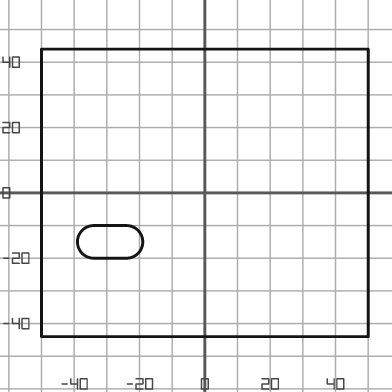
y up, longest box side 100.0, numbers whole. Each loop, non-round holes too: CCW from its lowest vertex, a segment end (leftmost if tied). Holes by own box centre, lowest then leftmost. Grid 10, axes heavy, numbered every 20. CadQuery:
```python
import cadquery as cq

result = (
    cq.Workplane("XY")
    .moveTo(-50.0, -44.0)
    .lineTo(50.0, -44.0)
    .lineTo(50.0, 44.0)
    .lineTo(-50.0, 44.0)
    .close()
    .moveTo(-34.0, -20.0)
    .lineTo(-24.0, -20.0)
    .threePointArc((-19.0, -15.0), (-24.0, -10.0))
    .lineTo(-34.0, -10.0)
    .threePointArc((-39.0, -15.0), (-34.0, -20.0))
    .close()
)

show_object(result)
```